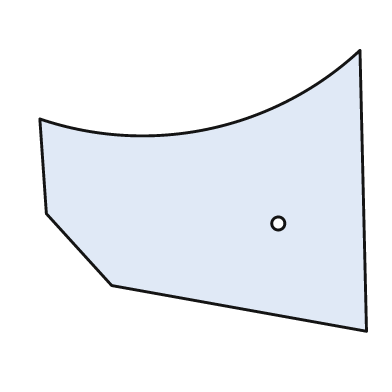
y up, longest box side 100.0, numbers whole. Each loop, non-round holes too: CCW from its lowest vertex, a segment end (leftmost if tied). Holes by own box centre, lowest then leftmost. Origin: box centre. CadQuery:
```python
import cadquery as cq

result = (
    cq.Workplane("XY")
    .moveTo(50.0, -43.0)
    .lineTo(48.0, 43.0)
    .threePointArc((2.0, 19.0), (-50.0, 22.0))
    .lineTo(-48.0, -7.0)
    .lineTo(-28.0, -29.0)
    .close()
    .moveTo(23.0, -10.0)
    .circle(2.0)
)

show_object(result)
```